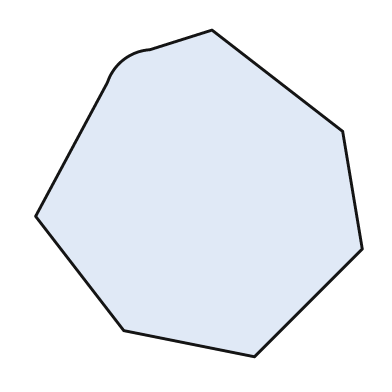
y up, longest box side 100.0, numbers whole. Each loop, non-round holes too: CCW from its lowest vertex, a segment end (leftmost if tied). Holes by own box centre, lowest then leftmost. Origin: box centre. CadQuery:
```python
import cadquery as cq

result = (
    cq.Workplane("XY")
    .moveTo(17.0, -50.0)
    .lineTo(50.0, -17.0)
    .lineTo(44.0, 19.0)
    .lineTo(4.0, 50.0)
    .lineTo(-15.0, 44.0)
    .threePointArc((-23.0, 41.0), (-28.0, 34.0))
    .lineTo(-50.0, -7.0)
    .lineTo(-23.0, -42.0)
    .close()
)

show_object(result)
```